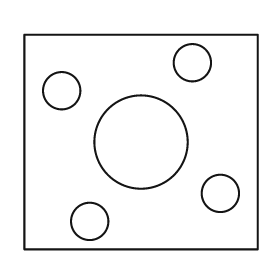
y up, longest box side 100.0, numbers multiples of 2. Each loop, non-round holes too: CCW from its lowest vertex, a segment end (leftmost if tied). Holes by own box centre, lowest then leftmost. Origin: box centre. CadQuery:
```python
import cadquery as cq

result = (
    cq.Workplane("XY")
    .moveTo(-50.0, -46.0)
    .lineTo(50.0, -46.0)
    .lineTo(50.0, 46.0)
    .lineTo(-50.0, 46.0)
    .close()
    .moveTo(-22.0, -34.0)
    .circle(8.0)
    .moveTo(34.0, -22.0)
    .circle(8.0)
    .moveTo(0.0, 0.0)
    .circle(20.0)
    .moveTo(-34.0, 22.0)
    .circle(8.0)
    .moveTo(22.0, 34.0)
    .circle(8.0)
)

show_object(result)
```